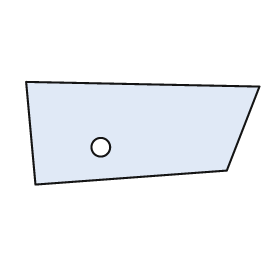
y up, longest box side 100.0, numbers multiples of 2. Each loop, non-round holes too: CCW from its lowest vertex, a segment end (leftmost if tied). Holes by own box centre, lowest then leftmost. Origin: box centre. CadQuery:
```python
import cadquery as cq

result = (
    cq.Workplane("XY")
    .moveTo(-46.0, -22.0)
    .lineTo(36.0, -16.0)
    .lineTo(50.0, 20.0)
    .lineTo(-50.0, 22.0)
    .close()
    .moveTo(-18.0, -6.0)
    .circle(4.0)
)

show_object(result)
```